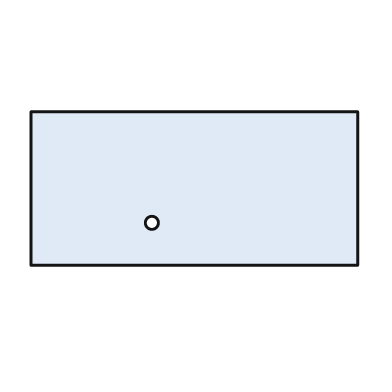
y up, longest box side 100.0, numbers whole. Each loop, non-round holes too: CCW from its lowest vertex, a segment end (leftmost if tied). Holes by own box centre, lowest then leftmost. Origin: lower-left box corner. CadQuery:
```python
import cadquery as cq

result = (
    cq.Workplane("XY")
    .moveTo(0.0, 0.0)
    .lineTo(100.0, 0.0)
    .lineTo(100.0, 47.0)
    .lineTo(0.0, 47.0)
    .close()
    .moveTo(37.0, 13.0)
    .circle(2.0)
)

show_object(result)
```